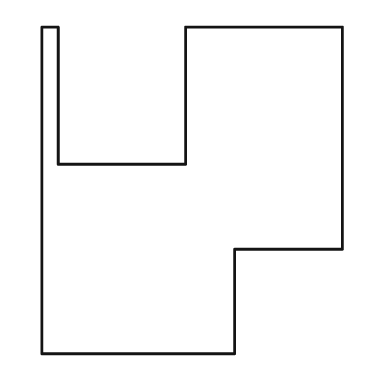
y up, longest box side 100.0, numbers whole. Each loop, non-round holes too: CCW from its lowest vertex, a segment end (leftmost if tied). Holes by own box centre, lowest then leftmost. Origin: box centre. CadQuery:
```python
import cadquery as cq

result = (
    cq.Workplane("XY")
    .moveTo(-46.0, -50.0)
    .lineTo(13.0, -50.0)
    .lineTo(13.0, -18.0)
    .lineTo(46.0, -18.0)
    .lineTo(46.0, 50.0)
    .lineTo(-2.0, 50.0)
    .lineTo(-2.0, 8.0)
    .lineTo(-41.0, 8.0)
    .lineTo(-41.0, 50.0)
    .lineTo(-46.0, 50.0)
    .close()
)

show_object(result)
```